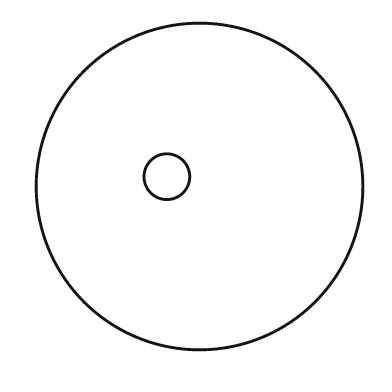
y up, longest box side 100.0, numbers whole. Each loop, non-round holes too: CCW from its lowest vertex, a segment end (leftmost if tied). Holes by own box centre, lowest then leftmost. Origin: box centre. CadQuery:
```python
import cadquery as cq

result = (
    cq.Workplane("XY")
    .moveTo(0.0, 0.0)
    .circle(50.0)
    .moveTo(-10.0, 3.0)
    .circle(7.0)
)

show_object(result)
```